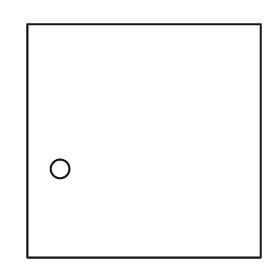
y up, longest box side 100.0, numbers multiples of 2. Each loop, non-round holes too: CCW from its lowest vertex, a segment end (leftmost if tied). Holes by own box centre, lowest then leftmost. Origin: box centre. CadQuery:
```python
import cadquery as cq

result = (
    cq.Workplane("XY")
    .moveTo(-50.0, -50.0)
    .lineTo(50.0, -50.0)
    .lineTo(50.0, 50.0)
    .lineTo(-50.0, 50.0)
    .close()
    .moveTo(-36.0, -12.0)
    .circle(4.0)
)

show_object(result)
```